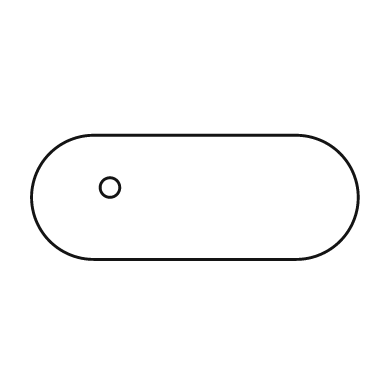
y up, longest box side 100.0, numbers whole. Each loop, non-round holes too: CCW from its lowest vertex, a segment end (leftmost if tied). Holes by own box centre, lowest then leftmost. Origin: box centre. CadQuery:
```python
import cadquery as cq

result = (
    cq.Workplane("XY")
    .moveTo(-31.0, -19.0)
    .lineTo(31.0, -19.0)
    .threePointArc((50.0, 0.0), (31.0, 19.0))
    .lineTo(-31.0, 19.0)
    .threePointArc((-50.0, 0.0), (-31.0, -19.0))
    .close()
    .moveTo(-26.0, 3.0)
    .circle(3.0)
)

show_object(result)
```